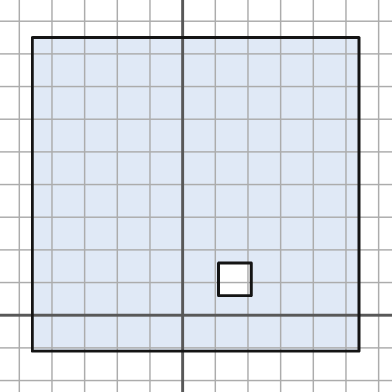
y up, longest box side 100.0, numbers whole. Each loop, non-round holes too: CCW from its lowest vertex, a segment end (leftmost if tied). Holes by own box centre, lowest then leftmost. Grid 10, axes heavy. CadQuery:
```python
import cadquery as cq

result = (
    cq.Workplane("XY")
    .moveTo(-46.0, -11.0)
    .lineTo(54.0, -11.0)
    .lineTo(54.0, 85.0)
    .lineTo(-46.0, 85.0)
    .close()
    .moveTo(11.0, 6.0)
    .lineTo(21.0, 6.0)
    .lineTo(21.0, 16.0)
    .lineTo(11.0, 16.0)
    .close()
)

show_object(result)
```